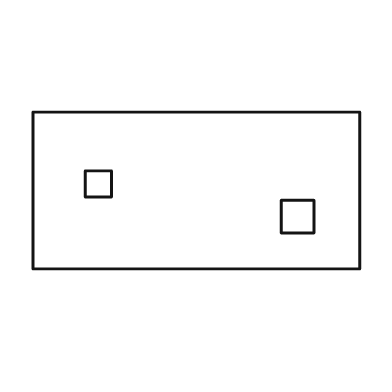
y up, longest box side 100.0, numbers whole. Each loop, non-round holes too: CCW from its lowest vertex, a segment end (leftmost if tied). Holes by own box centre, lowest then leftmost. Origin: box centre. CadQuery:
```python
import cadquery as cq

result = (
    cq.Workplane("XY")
    .moveTo(-50.0, -24.0)
    .lineTo(50.0, -24.0)
    .lineTo(50.0, 24.0)
    .lineTo(-50.0, 24.0)
    .close()
    .moveTo(26.0, -13.0)
    .lineTo(36.0, -13.0)
    .lineTo(36.0, -3.0)
    .lineTo(26.0, -3.0)
    .close()
    .moveTo(-34.0, -2.0)
    .lineTo(-26.0, -2.0)
    .lineTo(-26.0, 6.0)
    .lineTo(-34.0, 6.0)
    .close()
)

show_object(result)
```